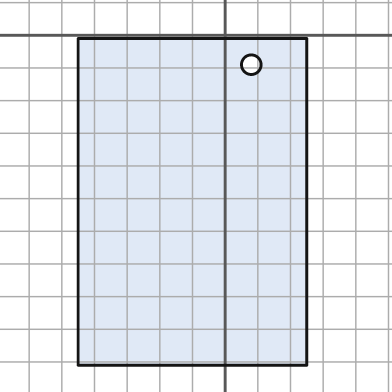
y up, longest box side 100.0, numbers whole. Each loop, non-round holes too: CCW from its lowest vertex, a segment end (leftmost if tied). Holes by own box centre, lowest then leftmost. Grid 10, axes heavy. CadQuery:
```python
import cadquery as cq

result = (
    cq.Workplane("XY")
    .moveTo(-45.0, -101.0)
    .lineTo(25.0, -101.0)
    .lineTo(25.0, -1.0)
    .lineTo(-45.0, -1.0)
    .close()
    .moveTo(8.0, -9.0)
    .circle(3.0)
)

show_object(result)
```